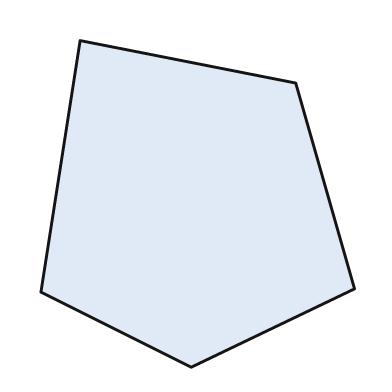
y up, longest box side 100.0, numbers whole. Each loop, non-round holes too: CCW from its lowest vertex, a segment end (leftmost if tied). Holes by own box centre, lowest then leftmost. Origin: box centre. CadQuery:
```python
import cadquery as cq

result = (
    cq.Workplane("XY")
    .moveTo(-2.0, -50.0)
    .lineTo(48.0, -26.0)
    .lineTo(30.0, 37.0)
    .lineTo(-36.0, 50.0)
    .lineTo(-48.0, -27.0)
    .close()
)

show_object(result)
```